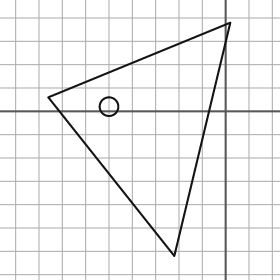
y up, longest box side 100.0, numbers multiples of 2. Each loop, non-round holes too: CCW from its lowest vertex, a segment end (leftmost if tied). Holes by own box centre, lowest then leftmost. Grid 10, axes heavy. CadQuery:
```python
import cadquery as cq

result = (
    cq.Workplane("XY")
    .moveTo(-22.0, -62.0)
    .lineTo(2.0, 38.0)
    .lineTo(-76.0, 6.0)
    .close()
    .moveTo(-50.0, 2.0)
    .circle(4.0)
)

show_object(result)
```